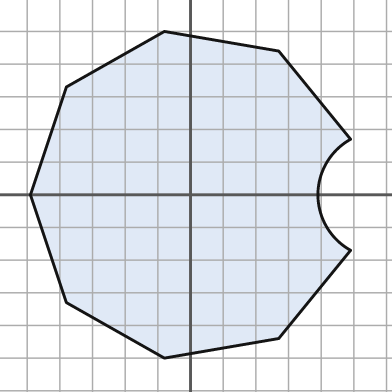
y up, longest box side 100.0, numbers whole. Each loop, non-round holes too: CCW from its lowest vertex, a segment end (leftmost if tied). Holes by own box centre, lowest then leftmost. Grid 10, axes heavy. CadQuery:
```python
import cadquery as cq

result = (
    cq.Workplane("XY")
    .moveTo(-8.0, -50.0)
    .lineTo(27.0, -44.0)
    .lineTo(49.0, -17.0)
    .threePointArc((39.0, 0.0), (49.0, 17.0))
    .lineTo(27.0, 44.0)
    .lineTo(-8.0, 50.0)
    .lineTo(-38.0, 33.0)
    .lineTo(-49.0, 0.0)
    .lineTo(-38.0, -33.0)
    .close()
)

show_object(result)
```